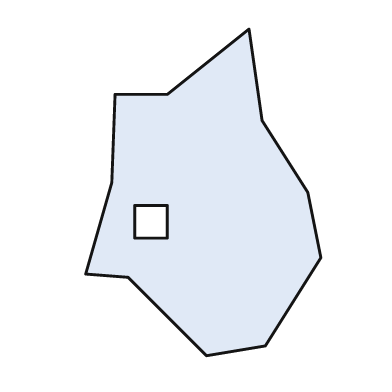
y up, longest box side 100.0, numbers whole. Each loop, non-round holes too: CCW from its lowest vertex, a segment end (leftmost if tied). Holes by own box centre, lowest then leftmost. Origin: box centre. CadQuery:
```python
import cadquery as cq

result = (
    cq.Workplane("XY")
    .moveTo(1.0, -50.0)
    .lineTo(19.0, -47.0)
    .lineTo(36.0, -20.0)
    .lineTo(32.0, 0.0)
    .lineTo(18.0, 22.0)
    .lineTo(14.0, 50.0)
    .lineTo(-11.0, 30.0)
    .lineTo(-27.0, 30.0)
    .lineTo(-28.0, 3.0)
    .lineTo(-36.0, -25.0)
    .lineTo(-23.0, -26.0)
    .close()
    .moveTo(-21.0, -14.0)
    .lineTo(-11.0, -14.0)
    .lineTo(-11.0, -4.0)
    .lineTo(-21.0, -4.0)
    .close()
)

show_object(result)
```